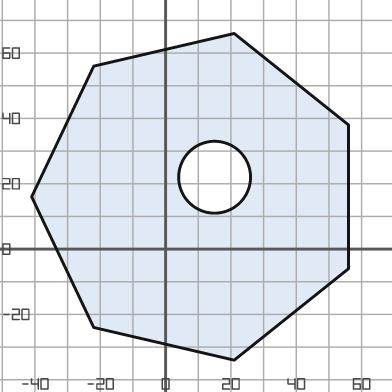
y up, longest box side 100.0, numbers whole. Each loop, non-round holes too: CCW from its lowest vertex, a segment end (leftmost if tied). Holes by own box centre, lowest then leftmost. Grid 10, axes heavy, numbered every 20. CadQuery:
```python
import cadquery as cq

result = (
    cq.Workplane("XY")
    .moveTo(21.0, -34.0)
    .lineTo(56.0, -6.0)
    .lineTo(56.0, 38.0)
    .lineTo(21.0, 66.0)
    .lineTo(-22.0, 56.0)
    .lineTo(-41.0, 16.0)
    .lineTo(-22.0, -24.0)
    .close()
    .moveTo(15.0, 22.0)
    .circle(11.0)
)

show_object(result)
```